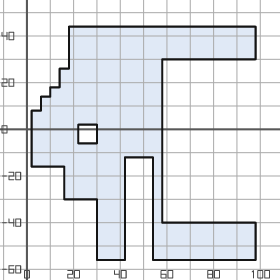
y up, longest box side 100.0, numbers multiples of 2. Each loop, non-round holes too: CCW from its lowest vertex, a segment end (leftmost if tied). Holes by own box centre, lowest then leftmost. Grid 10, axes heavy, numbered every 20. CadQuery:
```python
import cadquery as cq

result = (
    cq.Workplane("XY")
    .moveTo(30.0, -56.0)
    .lineTo(42.0, -56.0)
    .lineTo(42.0, -12.0)
    .lineTo(54.0, -12.0)
    .lineTo(54.0, -56.0)
    .lineTo(98.0, -56.0)
    .lineTo(98.0, -40.0)
    .lineTo(58.0, -40.0)
    .lineTo(58.0, 30.0)
    .lineTo(98.0, 30.0)
    .lineTo(98.0, 44.0)
    .lineTo(18.0, 44.0)
    .lineTo(18.0, 26.0)
    .lineTo(14.0, 26.0)
    .lineTo(14.0, 18.0)
    .lineTo(10.0, 18.0)
    .lineTo(10.0, 14.0)
    .lineTo(6.0, 14.0)
    .lineTo(6.0, 8.0)
    .lineTo(2.0, 8.0)
    .lineTo(2.0, -16.0)
    .lineTo(16.0, -16.0)
    .lineTo(16.0, -30.0)
    .lineTo(30.0, -30.0)
    .close()
    .moveTo(22.0, -6.0)
    .lineTo(30.0, -6.0)
    .lineTo(30.0, 2.0)
    .lineTo(22.0, 2.0)
    .close()
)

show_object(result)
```